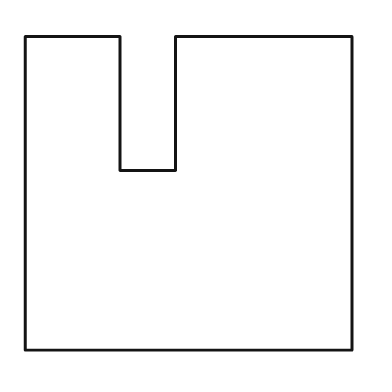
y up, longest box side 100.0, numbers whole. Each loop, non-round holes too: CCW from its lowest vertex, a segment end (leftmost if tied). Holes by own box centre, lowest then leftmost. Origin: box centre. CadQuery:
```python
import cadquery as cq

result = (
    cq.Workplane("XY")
    .moveTo(-50.0, -48.0)
    .lineTo(50.0, -48.0)
    .lineTo(50.0, 48.0)
    .lineTo(-4.0, 48.0)
    .lineTo(-4.0, 7.0)
    .lineTo(-21.0, 7.0)
    .lineTo(-21.0, 48.0)
    .lineTo(-50.0, 48.0)
    .close()
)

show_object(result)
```